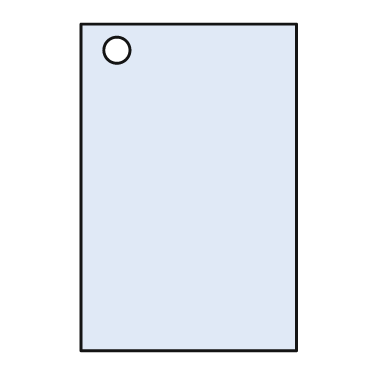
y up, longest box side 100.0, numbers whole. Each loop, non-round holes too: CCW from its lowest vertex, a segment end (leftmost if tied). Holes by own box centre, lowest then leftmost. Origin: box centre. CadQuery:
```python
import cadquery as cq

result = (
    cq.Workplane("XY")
    .moveTo(-33.0, -50.0)
    .lineTo(33.0, -50.0)
    .lineTo(33.0, 50.0)
    .lineTo(-33.0, 50.0)
    .close()
    .moveTo(-22.0, 42.0)
    .circle(4.0)
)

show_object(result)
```